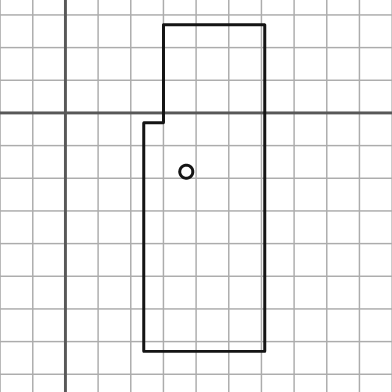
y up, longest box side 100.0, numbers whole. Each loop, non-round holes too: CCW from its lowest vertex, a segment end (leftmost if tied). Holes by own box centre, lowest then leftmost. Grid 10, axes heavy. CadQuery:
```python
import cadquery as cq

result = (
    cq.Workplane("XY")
    .moveTo(24.0, -73.0)
    .lineTo(61.0, -73.0)
    .lineTo(61.0, 27.0)
    .lineTo(30.0, 27.0)
    .lineTo(30.0, -3.0)
    .lineTo(24.0, -3.0)
    .close()
    .moveTo(37.0, -18.0)
    .circle(2.0)
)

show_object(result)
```